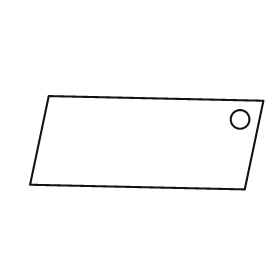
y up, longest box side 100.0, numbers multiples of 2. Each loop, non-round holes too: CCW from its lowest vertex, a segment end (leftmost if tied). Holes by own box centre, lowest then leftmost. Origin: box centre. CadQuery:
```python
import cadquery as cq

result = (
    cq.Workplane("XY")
    .moveTo(42.0, -20.0)
    .lineTo(50.0, 18.0)
    .lineTo(-42.0, 20.0)
    .lineTo(-50.0, -18.0)
    .close()
    .moveTo(40.0, 10.0)
    .circle(4.0)
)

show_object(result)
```